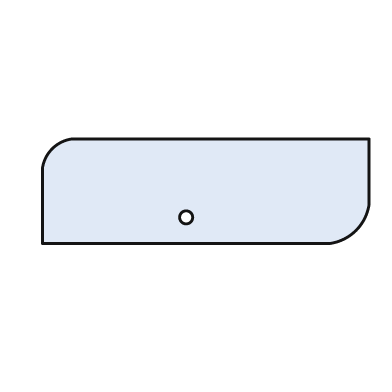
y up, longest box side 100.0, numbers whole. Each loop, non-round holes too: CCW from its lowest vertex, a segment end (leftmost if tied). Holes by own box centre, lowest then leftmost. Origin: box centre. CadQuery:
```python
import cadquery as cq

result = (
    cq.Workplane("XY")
    .moveTo(-50.0, -16.0)
    .lineTo(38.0, -16.0)
    .threePointArc((46.0, -12.0), (50.0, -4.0))
    .lineTo(50.0, 16.0)
    .lineTo(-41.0, 16.0)
    .threePointArc((-47.0, 13.0), (-50.0, 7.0))
    .close()
    .moveTo(-6.0, -8.0)
    .circle(2.0)
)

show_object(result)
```